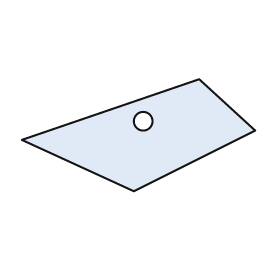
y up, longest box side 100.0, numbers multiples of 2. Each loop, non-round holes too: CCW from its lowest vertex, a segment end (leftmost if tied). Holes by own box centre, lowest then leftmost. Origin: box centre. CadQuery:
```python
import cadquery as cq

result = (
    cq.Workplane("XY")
    .moveTo(-2.0, -24.0)
    .lineTo(50.0, 2.0)
    .lineTo(26.0, 24.0)
    .lineTo(-50.0, -2.0)
    .close()
    .moveTo(2.0, 6.0)
    .circle(4.0)
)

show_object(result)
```